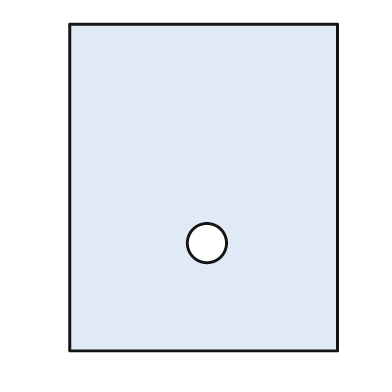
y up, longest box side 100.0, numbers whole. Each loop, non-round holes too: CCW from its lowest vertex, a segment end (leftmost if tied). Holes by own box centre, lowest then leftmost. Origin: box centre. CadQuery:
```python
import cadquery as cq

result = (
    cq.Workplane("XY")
    .moveTo(-41.0, -50.0)
    .lineTo(41.0, -50.0)
    .lineTo(41.0, 50.0)
    .lineTo(-41.0, 50.0)
    .close()
    .moveTo(1.0, -17.0)
    .circle(6.0)
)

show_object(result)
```